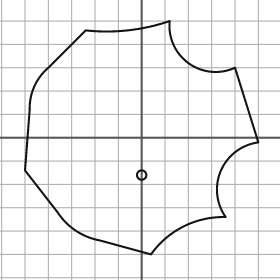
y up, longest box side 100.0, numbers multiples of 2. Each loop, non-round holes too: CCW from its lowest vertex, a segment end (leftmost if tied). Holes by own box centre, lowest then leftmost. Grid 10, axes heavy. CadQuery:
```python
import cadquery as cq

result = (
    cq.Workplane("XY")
    .moveTo(4.0, -50.0)
    .threePointArc((18.0, -38.0), (36.0, -34.0))
    .threePointArc((34.0, -14.0), (50.0, -2.0))
    .lineTo(40.0, 30.0)
    .threePointArc((20.0, 32.0), (12.0, 50.0))
    .threePointArc((-6.0, 46.0), (-24.0, 46.0))
    .lineTo(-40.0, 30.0)
    .threePointArc((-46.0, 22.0), (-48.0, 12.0))
    .lineTo(-50.0, -14.0)
    .lineTo(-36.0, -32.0)
    .threePointArc((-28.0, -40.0), (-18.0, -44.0))
    .close()
    .moveTo(0.0, -16.0)
    .circle(2.0)
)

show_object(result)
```